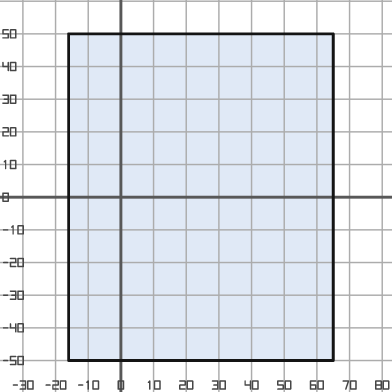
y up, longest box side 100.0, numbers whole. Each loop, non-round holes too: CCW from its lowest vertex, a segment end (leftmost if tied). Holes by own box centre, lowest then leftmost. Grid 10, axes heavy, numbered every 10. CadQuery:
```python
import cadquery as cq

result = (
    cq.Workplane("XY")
    .moveTo(-16.0, -50.0)
    .lineTo(65.0, -50.0)
    .lineTo(65.0, 50.0)
    .lineTo(-16.0, 50.0)
    .close()
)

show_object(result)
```